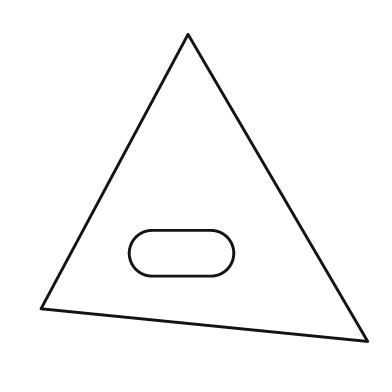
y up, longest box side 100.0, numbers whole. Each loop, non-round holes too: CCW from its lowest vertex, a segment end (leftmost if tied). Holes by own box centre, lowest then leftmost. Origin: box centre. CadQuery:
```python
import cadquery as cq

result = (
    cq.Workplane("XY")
    .moveTo(50.0, -47.0)
    .lineTo(-5.0, 47.0)
    .lineTo(-50.0, -37.0)
    .close()
    .moveTo(-16.0, -27.0)
    .lineTo(2.0, -27.0)
    .threePointArc((9.0, -20.0), (2.0, -13.0))
    .lineTo(-16.0, -13.0)
    .threePointArc((-23.0, -20.0), (-16.0, -27.0))
    .close()
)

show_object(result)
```